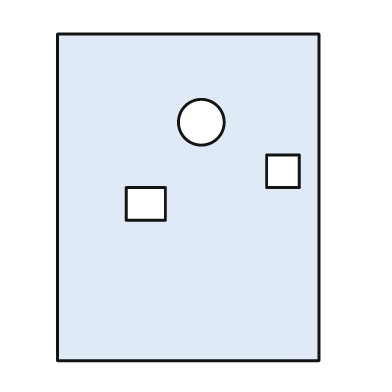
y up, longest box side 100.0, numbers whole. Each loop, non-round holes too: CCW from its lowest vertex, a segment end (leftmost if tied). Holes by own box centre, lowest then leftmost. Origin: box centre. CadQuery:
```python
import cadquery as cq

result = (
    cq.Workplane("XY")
    .moveTo(-40.0, -50.0)
    .lineTo(40.0, -50.0)
    .lineTo(40.0, 50.0)
    .lineTo(-40.0, 50.0)
    .close()
    .moveTo(-19.0, -7.0)
    .lineTo(-7.0, -7.0)
    .lineTo(-7.0, 3.0)
    .lineTo(-19.0, 3.0)
    .close()
    .moveTo(24.0, 3.0)
    .lineTo(34.0, 3.0)
    .lineTo(34.0, 13.0)
    .lineTo(24.0, 13.0)
    .close()
    .moveTo(4.0, 23.0)
    .circle(7.0)
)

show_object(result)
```